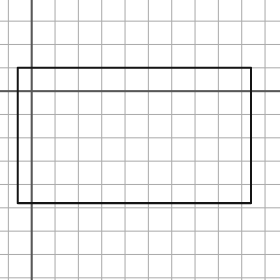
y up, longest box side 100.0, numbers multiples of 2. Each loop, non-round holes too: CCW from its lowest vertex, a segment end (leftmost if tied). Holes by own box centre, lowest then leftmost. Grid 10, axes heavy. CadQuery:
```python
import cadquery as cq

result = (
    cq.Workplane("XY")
    .moveTo(-6.0, -48.0)
    .lineTo(94.0, -48.0)
    .lineTo(94.0, 10.0)
    .lineTo(-6.0, 10.0)
    .close()
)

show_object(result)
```